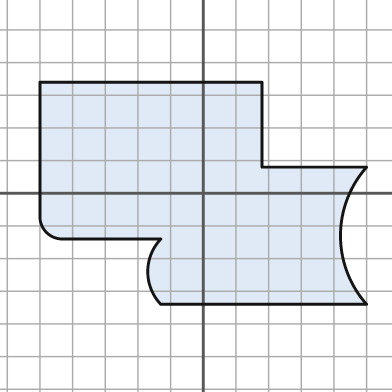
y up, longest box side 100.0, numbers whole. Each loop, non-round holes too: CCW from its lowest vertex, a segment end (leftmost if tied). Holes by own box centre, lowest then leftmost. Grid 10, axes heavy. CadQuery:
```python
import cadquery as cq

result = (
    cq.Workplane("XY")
    .moveTo(-13.0, -34.0)
    .lineTo(50.0, -34.0)
    .threePointArc((42.0, -13.0), (50.0, 8.0))
    .lineTo(18.0, 8.0)
    .lineTo(18.0, 34.0)
    .lineTo(-50.0, 34.0)
    .lineTo(-50.0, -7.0)
    .threePointArc((-48.0, -12.0), (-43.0, -14.0))
    .lineTo(-13.0, -14.0)
    .threePointArc((-17.0, -24.0), (-13.0, -34.0))
    .close()
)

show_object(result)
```